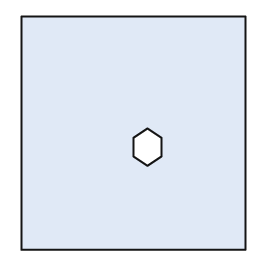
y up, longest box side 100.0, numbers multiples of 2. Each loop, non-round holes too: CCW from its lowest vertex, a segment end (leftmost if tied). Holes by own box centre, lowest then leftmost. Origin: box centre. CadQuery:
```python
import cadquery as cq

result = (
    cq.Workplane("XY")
    .moveTo(-48.0, -50.0)
    .lineTo(48.0, -50.0)
    .lineTo(48.0, 50.0)
    .lineTo(-48.0, 50.0)
    .close()
    .moveTo(6.0, -14.0)
    .lineTo(12.0, -10.0)
    .lineTo(12.0, -2.0)
    .lineTo(6.0, 2.0)
    .lineTo(0.0, -2.0)
    .lineTo(0.0, -10.0)
    .close()
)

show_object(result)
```